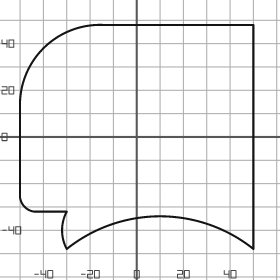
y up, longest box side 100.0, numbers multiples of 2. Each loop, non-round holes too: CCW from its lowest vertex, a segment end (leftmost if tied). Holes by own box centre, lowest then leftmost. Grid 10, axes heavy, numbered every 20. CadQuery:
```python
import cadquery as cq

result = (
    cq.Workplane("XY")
    .moveTo(-30.0, -48.0)
    .threePointArc((10.0, -34.0), (50.0, -48.0))
    .lineTo(50.0, 48.0)
    .lineTo(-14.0, 48.0)
    .threePointArc((-40.0, 38.0), (-50.0, 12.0))
    .lineTo(-50.0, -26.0)
    .threePointArc((-48.0, -30.0), (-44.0, -32.0))
    .lineTo(-30.0, -32.0)
    .threePointArc((-32.0, -40.0), (-30.0, -48.0))
    .close()
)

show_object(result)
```